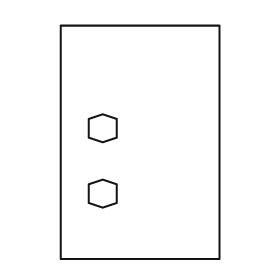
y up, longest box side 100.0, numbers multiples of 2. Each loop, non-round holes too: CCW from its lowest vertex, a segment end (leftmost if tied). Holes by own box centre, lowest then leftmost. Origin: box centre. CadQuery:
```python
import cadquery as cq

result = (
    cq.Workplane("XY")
    .moveTo(-34.0, -50.0)
    .lineTo(34.0, -50.0)
    .lineTo(34.0, 50.0)
    .lineTo(-34.0, 50.0)
    .close()
    .moveTo(-16.0, -28.0)
    .lineTo(-10.0, -26.0)
    .lineTo(-10.0, -18.0)
    .lineTo(-16.0, -16.0)
    .lineTo(-22.0, -18.0)
    .lineTo(-22.0, -26.0)
    .close()
    .moveTo(-16.0, 0.0)
    .lineTo(-10.0, 2.0)
    .lineTo(-10.0, 10.0)
    .lineTo(-16.0, 12.0)
    .lineTo(-22.0, 10.0)
    .lineTo(-22.0, 2.0)
    .close()
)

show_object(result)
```